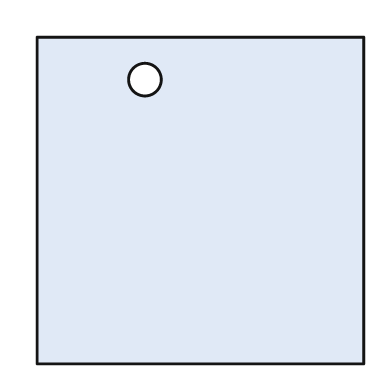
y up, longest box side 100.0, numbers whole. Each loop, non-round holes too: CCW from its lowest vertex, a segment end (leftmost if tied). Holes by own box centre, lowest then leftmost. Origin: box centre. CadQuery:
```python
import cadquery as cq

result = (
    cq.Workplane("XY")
    .moveTo(-50.0, -50.0)
    .lineTo(50.0, -50.0)
    .lineTo(50.0, 50.0)
    .lineTo(-50.0, 50.0)
    .close()
    .moveTo(-17.0, 37.0)
    .circle(5.0)
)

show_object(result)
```